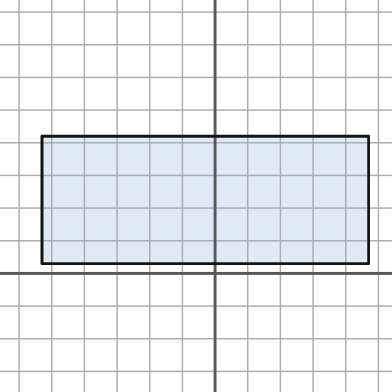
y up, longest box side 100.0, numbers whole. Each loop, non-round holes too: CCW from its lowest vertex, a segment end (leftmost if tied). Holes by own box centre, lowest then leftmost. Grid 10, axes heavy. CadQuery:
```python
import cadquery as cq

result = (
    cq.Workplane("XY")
    .moveTo(-53.0, 3.0)
    .lineTo(47.0, 3.0)
    .lineTo(47.0, 42.0)
    .lineTo(-53.0, 42.0)
    .close()
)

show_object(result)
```